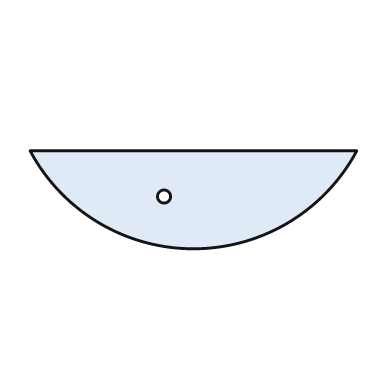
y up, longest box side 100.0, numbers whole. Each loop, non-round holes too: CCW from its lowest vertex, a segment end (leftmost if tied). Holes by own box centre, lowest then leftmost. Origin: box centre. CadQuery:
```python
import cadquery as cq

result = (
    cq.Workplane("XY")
    .moveTo(-50.0, 15.0)
    .threePointArc((0.0, -15.0), (50.0, 15.0))
    .close()
    .moveTo(-9.0, 1.0)
    .circle(2.0)
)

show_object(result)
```